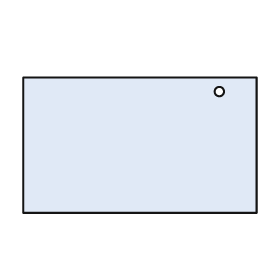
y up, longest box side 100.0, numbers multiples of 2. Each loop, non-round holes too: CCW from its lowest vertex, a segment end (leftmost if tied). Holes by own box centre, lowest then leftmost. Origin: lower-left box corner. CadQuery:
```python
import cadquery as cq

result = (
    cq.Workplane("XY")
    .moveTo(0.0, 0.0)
    .lineTo(100.0, 0.0)
    .lineTo(100.0, 58.0)
    .lineTo(0.0, 58.0)
    .close()
    .moveTo(84.0, 52.0)
    .circle(2.0)
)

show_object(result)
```